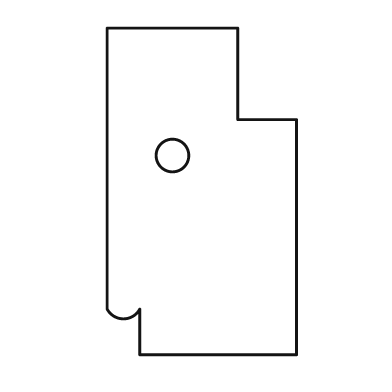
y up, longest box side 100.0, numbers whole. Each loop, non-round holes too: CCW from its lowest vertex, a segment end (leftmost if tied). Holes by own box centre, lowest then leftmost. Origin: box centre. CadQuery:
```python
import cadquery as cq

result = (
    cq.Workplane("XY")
    .moveTo(-19.0, -50.0)
    .lineTo(29.0, -50.0)
    .lineTo(29.0, 22.0)
    .lineTo(11.0, 22.0)
    .lineTo(11.0, 50.0)
    .lineTo(-29.0, 50.0)
    .lineTo(-29.0, -36.0)
    .threePointArc((-24.0, -39.0), (-19.0, -36.0))
    .close()
    .moveTo(-9.0, 11.0)
    .circle(5.0)
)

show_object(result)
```